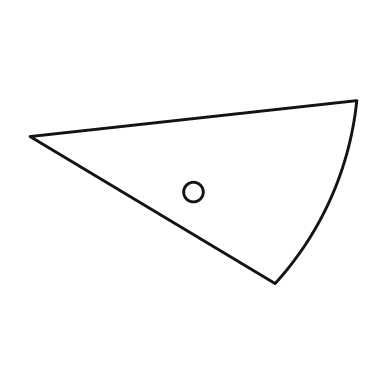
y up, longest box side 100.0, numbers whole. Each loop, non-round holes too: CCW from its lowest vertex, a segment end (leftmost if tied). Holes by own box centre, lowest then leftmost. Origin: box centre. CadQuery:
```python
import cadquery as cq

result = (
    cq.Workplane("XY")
    .moveTo(25.0, -28.0)
    .threePointArc((42.0, -2.0), (50.0, 28.0))
    .lineTo(-50.0, 17.0)
    .close()
    .moveTo(0.0, 0.0)
    .circle(3.0)
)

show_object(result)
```